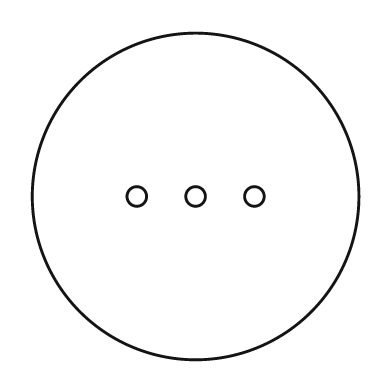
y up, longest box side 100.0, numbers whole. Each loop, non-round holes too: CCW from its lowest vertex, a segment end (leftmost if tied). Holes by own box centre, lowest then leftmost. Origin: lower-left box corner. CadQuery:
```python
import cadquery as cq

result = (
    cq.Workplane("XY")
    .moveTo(50.0, 50.0)
    .circle(50.0)
    .moveTo(32.0, 50.0)
    .circle(3.0)
    .moveTo(50.0, 50.0)
    .circle(3.0)
    .moveTo(68.0, 50.0)
    .circle(3.0)
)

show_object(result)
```